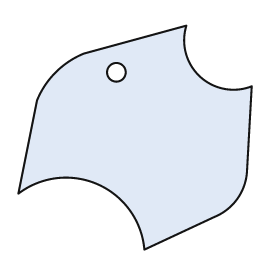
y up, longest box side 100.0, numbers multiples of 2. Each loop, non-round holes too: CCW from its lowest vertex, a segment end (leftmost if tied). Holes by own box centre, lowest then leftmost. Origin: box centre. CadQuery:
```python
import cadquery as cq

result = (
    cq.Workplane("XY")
    .moveTo(4.0, -48.0)
    .lineTo(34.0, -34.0)
    .threePointArc((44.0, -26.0), (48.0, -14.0))
    .lineTo(50.0, 22.0)
    .threePointArc((28.0, 26.0), (22.0, 48.0))
    .lineTo(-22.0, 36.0)
    .threePointArc((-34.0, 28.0), (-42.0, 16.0))
    .lineTo(-50.0, -24.0)
    .threePointArc((-16.0, -20.0), (4.0, -48.0))
    .close()
    .moveTo(-8.0, 28.0)
    .circle(4.0)
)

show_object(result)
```